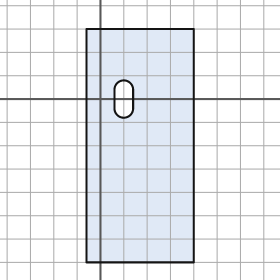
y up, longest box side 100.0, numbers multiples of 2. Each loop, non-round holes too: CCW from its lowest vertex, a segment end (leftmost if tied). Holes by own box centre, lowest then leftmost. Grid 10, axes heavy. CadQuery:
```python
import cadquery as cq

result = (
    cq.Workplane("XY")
    .moveTo(-6.0, -70.0)
    .lineTo(40.0, -70.0)
    .lineTo(40.0, 30.0)
    .lineTo(-6.0, 30.0)
    .close()
    .moveTo(6.0, -4.0)
    .threePointArc((10.0, -8.0), (14.0, -4.0))
    .lineTo(14.0, 4.0)
    .threePointArc((10.0, 8.0), (6.0, 4.0))
    .close()
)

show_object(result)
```